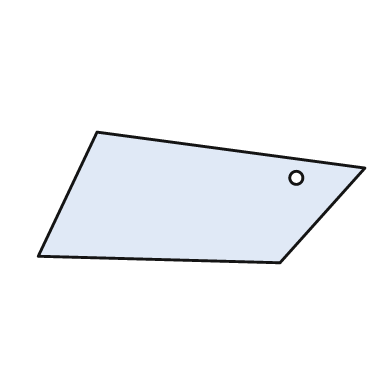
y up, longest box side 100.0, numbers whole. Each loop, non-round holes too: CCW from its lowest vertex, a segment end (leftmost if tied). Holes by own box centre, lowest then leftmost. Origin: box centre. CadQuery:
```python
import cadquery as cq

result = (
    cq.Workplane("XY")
    .moveTo(24.0, -20.0)
    .lineTo(50.0, 9.0)
    .lineTo(-32.0, 20.0)
    .lineTo(-50.0, -18.0)
    .close()
    .moveTo(29.0, 6.0)
    .circle(2.0)
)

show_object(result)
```